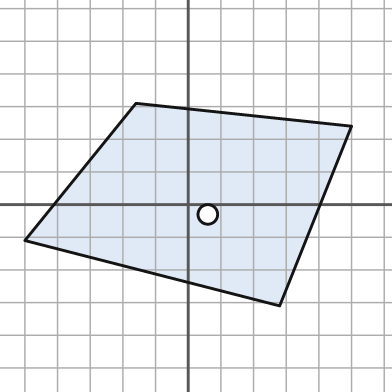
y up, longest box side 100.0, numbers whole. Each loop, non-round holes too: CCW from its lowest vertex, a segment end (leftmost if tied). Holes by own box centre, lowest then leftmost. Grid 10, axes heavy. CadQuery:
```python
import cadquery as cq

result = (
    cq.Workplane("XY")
    .moveTo(28.0, -31.0)
    .lineTo(50.0, 24.0)
    .lineTo(-16.0, 31.0)
    .lineTo(-50.0, -11.0)
    .close()
    .moveTo(6.0, -3.0)
    .circle(3.0)
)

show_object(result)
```